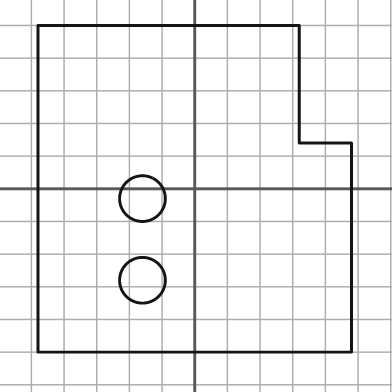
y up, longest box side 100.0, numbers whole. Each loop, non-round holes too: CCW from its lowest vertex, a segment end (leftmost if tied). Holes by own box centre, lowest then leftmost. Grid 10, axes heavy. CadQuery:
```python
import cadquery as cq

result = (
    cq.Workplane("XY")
    .moveTo(-48.0, -50.0)
    .lineTo(48.0, -50.0)
    .lineTo(48.0, 14.0)
    .lineTo(32.0, 14.0)
    .lineTo(32.0, 50.0)
    .lineTo(-48.0, 50.0)
    .close()
    .moveTo(-16.0, -28.0)
    .circle(7.0)
    .moveTo(-16.0, -3.0)
    .circle(7.0)
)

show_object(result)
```